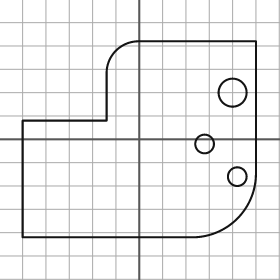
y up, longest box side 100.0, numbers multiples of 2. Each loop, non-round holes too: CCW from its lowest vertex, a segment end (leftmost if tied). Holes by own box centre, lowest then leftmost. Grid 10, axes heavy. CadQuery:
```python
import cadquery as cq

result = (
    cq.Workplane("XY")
    .moveTo(-50.0, -42.0)
    .lineTo(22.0, -42.0)
    .threePointArc((42.0, -34.0), (50.0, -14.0))
    .lineTo(50.0, 42.0)
    .lineTo(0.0, 42.0)
    .threePointArc((-10.0, 38.0), (-14.0, 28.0))
    .lineTo(-14.0, 8.0)
    .lineTo(-50.0, 8.0)
    .close()
    .moveTo(42.0, -16.0)
    .circle(4.0)
    .moveTo(28.0, -2.0)
    .circle(4.0)
    .moveTo(40.0, 20.0)
    .circle(6.0)
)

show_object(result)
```